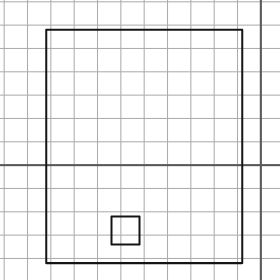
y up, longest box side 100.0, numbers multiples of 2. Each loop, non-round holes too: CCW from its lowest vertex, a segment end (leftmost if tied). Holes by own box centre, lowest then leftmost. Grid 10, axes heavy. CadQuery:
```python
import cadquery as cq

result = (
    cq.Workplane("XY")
    .moveTo(-92.0, -42.0)
    .lineTo(-8.0, -42.0)
    .lineTo(-8.0, 58.0)
    .lineTo(-92.0, 58.0)
    .close()
    .moveTo(-64.0, -34.0)
    .lineTo(-52.0, -34.0)
    .lineTo(-52.0, -22.0)
    .lineTo(-64.0, -22.0)
    .close()
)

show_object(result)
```